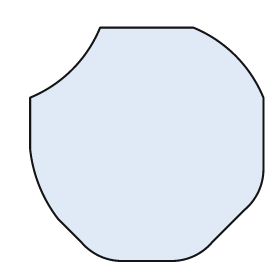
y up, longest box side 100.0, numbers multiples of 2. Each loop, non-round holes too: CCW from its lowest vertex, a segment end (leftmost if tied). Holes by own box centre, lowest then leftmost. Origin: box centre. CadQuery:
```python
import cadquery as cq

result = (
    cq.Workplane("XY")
    .moveTo(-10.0, -50.0)
    .lineTo(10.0, -50.0)
    .threePointArc((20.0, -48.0), (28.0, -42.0))
    .lineTo(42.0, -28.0)
    .threePointArc((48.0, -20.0), (50.0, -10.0))
    .lineTo(50.0, 20.0)
    .threePointArc((38.0, 38.0), (20.0, 50.0))
    .lineTo(-20.0, 50.0)
    .threePointArc((-32.0, 32.0), (-50.0, 20.0))
    .lineTo(-50.0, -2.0)
    .threePointArc((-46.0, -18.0), (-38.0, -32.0))
    .lineTo(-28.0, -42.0)
    .threePointArc((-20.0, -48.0), (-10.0, -50.0))
    .close()
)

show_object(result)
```